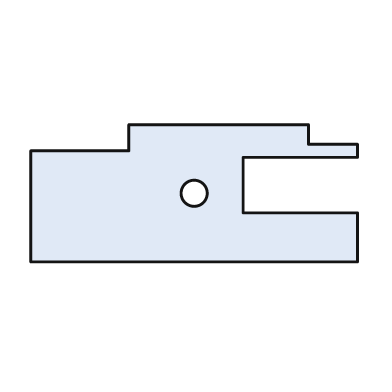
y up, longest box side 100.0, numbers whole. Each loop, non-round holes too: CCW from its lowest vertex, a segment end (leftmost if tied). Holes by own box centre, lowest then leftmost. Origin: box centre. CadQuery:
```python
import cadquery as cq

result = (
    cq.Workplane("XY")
    .moveTo(-50.0, -21.0)
    .lineTo(50.0, -21.0)
    .lineTo(50.0, -6.0)
    .lineTo(15.0, -6.0)
    .lineTo(15.0, 11.0)
    .lineTo(50.0, 11.0)
    .lineTo(50.0, 15.0)
    .lineTo(35.0, 15.0)
    .lineTo(35.0, 21.0)
    .lineTo(-20.0, 21.0)
    .lineTo(-20.0, 13.0)
    .lineTo(-50.0, 13.0)
    .close()
    .moveTo(0.0, 0.0)
    .circle(4.0)
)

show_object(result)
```